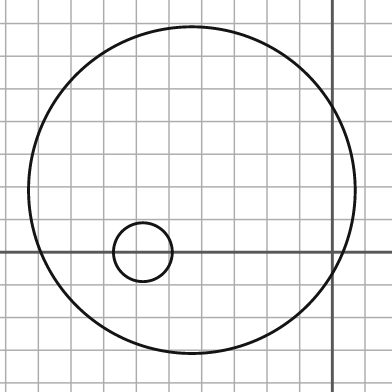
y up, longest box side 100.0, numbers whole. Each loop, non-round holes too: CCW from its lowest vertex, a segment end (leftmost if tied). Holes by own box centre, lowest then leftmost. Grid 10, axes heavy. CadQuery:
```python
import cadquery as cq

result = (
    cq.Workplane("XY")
    .moveTo(-43.0, 19.0)
    .circle(50.0)
    .moveTo(-58.0, 0.0)
    .circle(9.0)
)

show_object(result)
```